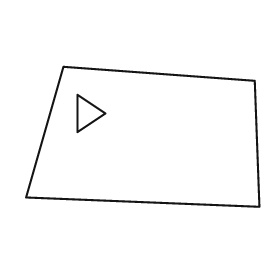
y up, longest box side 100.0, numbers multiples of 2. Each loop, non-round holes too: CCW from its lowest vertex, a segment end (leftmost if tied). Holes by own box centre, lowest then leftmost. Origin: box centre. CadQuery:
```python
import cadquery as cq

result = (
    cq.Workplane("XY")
    .moveTo(50.0, -30.0)
    .lineTo(48.0, 24.0)
    .lineTo(-34.0, 30.0)
    .lineTo(-50.0, -26.0)
    .close()
    .moveTo(-28.0, 2.0)
    .lineTo(-16.0, 10.0)
    .lineTo(-28.0, 18.0)
    .close()
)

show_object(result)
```